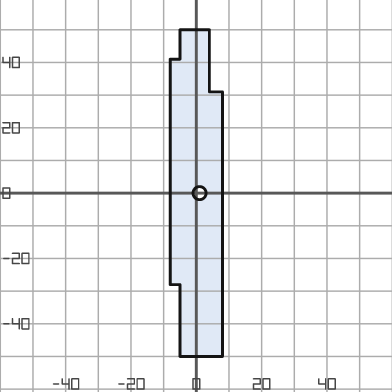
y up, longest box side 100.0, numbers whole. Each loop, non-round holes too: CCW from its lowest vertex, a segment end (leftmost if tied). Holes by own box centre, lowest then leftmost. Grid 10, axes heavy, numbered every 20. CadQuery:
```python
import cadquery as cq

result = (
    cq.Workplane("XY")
    .moveTo(-5.0, -50.0)
    .lineTo(8.0, -50.0)
    .lineTo(8.0, 31.0)
    .lineTo(4.0, 31.0)
    .lineTo(4.0, 50.0)
    .lineTo(-5.0, 50.0)
    .lineTo(-5.0, 41.0)
    .lineTo(-8.0, 41.0)
    .lineTo(-8.0, -28.0)
    .lineTo(-5.0, -28.0)
    .close()
    .moveTo(1.0, 0.0)
    .circle(2.0)
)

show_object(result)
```